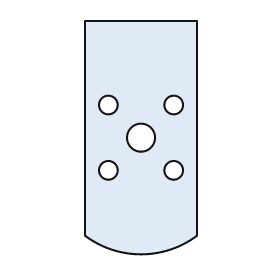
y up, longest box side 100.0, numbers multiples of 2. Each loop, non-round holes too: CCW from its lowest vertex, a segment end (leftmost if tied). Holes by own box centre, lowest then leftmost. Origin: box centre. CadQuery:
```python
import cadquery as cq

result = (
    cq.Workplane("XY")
    .moveTo(-24.0, -42.0)
    .threePointArc((0.0, -50.0), (24.0, -42.0))
    .lineTo(24.0, 50.0)
    .lineTo(-24.0, 50.0)
    .close()
    .moveTo(-14.0, -14.0)
    .circle(4.0)
    .moveTo(14.0, -14.0)
    .circle(4.0)
    .moveTo(0.0, 0.0)
    .circle(6.0)
    .moveTo(-14.0, 14.0)
    .circle(4.0)
    .moveTo(14.0, 14.0)
    .circle(4.0)
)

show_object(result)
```